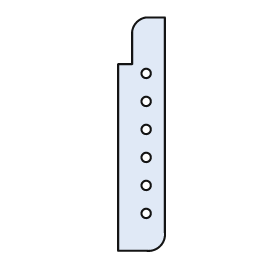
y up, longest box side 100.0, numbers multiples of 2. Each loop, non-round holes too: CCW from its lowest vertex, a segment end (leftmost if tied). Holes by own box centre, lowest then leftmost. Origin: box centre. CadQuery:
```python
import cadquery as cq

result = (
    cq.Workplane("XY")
    .moveTo(-10.0, -50.0)
    .lineTo(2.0, -50.0)
    .threePointArc((8.0, -48.0), (10.0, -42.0))
    .lineTo(10.0, 50.0)
    .lineTo(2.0, 50.0)
    .threePointArc((-2.0, 48.0), (-4.0, 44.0))
    .lineTo(-4.0, 30.0)
    .lineTo(-10.0, 30.0)
    .close()
    .moveTo(2.0, -34.0)
    .circle(2.0)
    .moveTo(2.0, -22.0)
    .circle(2.0)
    .moveTo(2.0, -10.0)
    .circle(2.0)
    .moveTo(2.0, 2.0)
    .circle(2.0)
    .moveTo(2.0, 14.0)
    .circle(2.0)
    .moveTo(2.0, 26.0)
    .circle(2.0)
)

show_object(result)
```